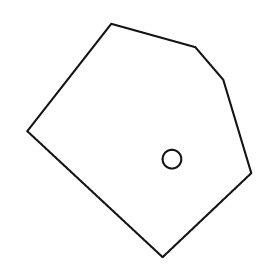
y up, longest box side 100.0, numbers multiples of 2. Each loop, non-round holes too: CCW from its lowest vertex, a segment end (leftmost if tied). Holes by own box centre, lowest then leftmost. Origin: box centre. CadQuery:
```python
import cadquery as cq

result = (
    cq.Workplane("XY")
    .moveTo(10.0, -50.0)
    .lineTo(48.0, -14.0)
    .lineTo(36.0, 26.0)
    .lineTo(24.0, 40.0)
    .lineTo(-12.0, 50.0)
    .lineTo(-48.0, 4.0)
    .close()
    .moveTo(14.0, -8.0)
    .circle(4.0)
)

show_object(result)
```